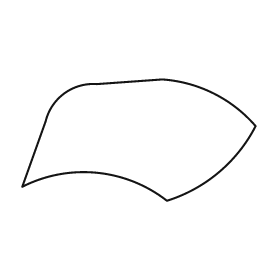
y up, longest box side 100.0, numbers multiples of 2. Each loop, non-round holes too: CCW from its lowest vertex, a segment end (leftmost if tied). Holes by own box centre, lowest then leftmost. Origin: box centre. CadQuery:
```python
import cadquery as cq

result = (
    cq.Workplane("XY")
    .moveTo(12.0, -26.0)
    .threePointArc((34.0, -14.0), (50.0, 6.0))
    .threePointArc((32.0, 20.0), (10.0, 26.0))
    .lineTo(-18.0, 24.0)
    .threePointArc((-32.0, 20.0), (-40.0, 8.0))
    .lineTo(-50.0, -20.0)
    .threePointArc((-18.0, -14.0), (12.0, -26.0))
    .close()
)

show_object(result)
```